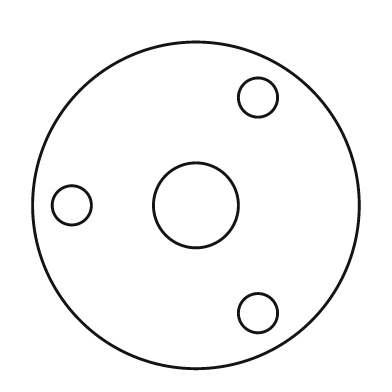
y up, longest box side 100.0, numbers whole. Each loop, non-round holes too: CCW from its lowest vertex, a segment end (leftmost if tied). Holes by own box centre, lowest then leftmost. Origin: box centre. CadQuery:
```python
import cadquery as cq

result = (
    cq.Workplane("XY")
    .moveTo(0.0, 0.0)
    .circle(50.0)
    .moveTo(19.0, -33.0)
    .circle(6.0)
    .moveTo(-38.0, 0.0)
    .circle(6.0)
    .moveTo(0.0, 0.0)
    .circle(13.0)
    .moveTo(19.0, 33.0)
    .circle(6.0)
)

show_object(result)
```